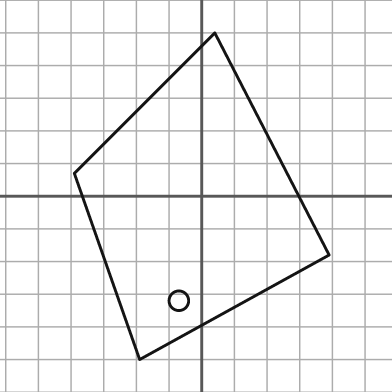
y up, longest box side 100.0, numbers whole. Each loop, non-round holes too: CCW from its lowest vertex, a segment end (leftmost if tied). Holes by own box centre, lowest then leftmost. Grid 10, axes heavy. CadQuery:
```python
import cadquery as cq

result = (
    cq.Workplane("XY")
    .moveTo(-19.0, -50.0)
    .lineTo(39.0, -18.0)
    .lineTo(4.0, 50.0)
    .lineTo(-39.0, 7.0)
    .close()
    .moveTo(-7.0, -32.0)
    .circle(3.0)
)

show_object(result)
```